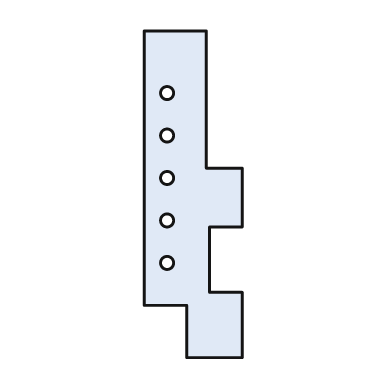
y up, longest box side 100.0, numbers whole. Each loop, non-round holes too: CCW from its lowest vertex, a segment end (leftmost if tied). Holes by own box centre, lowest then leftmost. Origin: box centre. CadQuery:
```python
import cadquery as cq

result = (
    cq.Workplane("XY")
    .moveTo(-2.0, -50.0)
    .lineTo(15.0, -50.0)
    .lineTo(15.0, -30.0)
    .lineTo(5.0, -30.0)
    .lineTo(5.0, -10.0)
    .lineTo(15.0, -10.0)
    .lineTo(15.0, 8.0)
    .lineTo(4.0, 8.0)
    .lineTo(4.0, 50.0)
    .lineTo(-15.0, 50.0)
    .lineTo(-15.0, -34.0)
    .lineTo(-2.0, -34.0)
    .close()
    .moveTo(-8.0, -21.0)
    .circle(2.0)
    .moveTo(-8.0, -8.0)
    .circle(2.0)
    .moveTo(-8.0, 5.0)
    .circle(2.0)
    .moveTo(-8.0, 18.0)
    .circle(2.0)
    .moveTo(-8.0, 31.0)
    .circle(2.0)
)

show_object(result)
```